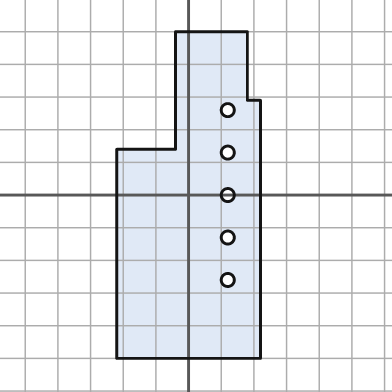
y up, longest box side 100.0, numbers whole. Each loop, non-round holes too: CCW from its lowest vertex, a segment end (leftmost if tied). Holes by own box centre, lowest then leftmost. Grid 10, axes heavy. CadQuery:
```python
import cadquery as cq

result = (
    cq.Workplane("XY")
    .moveTo(-22.0, -50.0)
    .lineTo(22.0, -50.0)
    .lineTo(22.0, 29.0)
    .lineTo(18.0, 29.0)
    .lineTo(18.0, 50.0)
    .lineTo(-4.0, 50.0)
    .lineTo(-4.0, 14.0)
    .lineTo(-22.0, 14.0)
    .close()
    .moveTo(12.0, -26.0)
    .circle(2.0)
    .moveTo(12.0, -13.0)
    .circle(2.0)
    .moveTo(12.0, 0.0)
    .circle(2.0)
    .moveTo(12.0, 13.0)
    .circle(2.0)
    .moveTo(12.0, 26.0)
    .circle(2.0)
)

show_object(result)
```